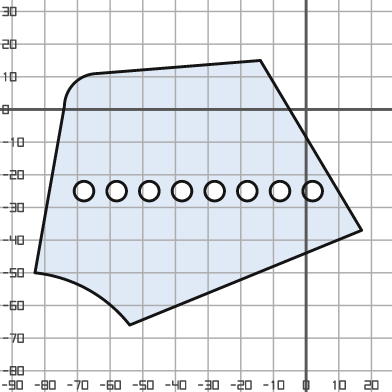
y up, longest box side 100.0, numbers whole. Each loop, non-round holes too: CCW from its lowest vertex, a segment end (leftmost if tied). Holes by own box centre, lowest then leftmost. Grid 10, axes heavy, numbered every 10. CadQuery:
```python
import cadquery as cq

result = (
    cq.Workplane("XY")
    .moveTo(-54.0, -66.0)
    .lineTo(17.0, -37.0)
    .lineTo(-14.0, 15.0)
    .lineTo(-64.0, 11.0)
    .threePointArc((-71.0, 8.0), (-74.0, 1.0))
    .lineTo(-83.0, -50.0)
    .threePointArc((-67.0, -55.0), (-54.0, -66.0))
    .close()
    .moveTo(-68.0, -25.0)
    .circle(3.0)
    .moveTo(-58.0, -25.0)
    .circle(3.0)
    .moveTo(-48.0, -25.0)
    .circle(3.0)
    .moveTo(-38.0, -25.0)
    .circle(3.0)
    .moveTo(-28.0, -25.0)
    .circle(3.0)
    .moveTo(-18.0, -25.0)
    .circle(3.0)
    .moveTo(-8.0, -25.0)
    .circle(3.0)
    .moveTo(2.0, -25.0)
    .circle(3.0)
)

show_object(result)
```